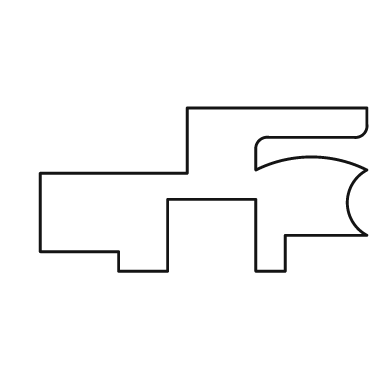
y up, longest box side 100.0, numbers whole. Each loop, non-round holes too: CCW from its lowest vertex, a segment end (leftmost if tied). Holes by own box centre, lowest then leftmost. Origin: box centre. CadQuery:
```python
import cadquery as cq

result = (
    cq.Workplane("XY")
    .moveTo(-26.0, -25.0)
    .lineTo(-11.0, -25.0)
    .lineTo(-11.0, -3.0)
    .lineTo(16.0, -3.0)
    .lineTo(16.0, -25.0)
    .lineTo(25.0, -25.0)
    .lineTo(25.0, -14.0)
    .lineTo(50.0, -14.0)
    .threePointArc((44.0, -4.0), (50.0, 6.0))
    .threePointArc((33.0, 10.0), (16.0, 6.0))
    .lineTo(16.0, 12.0)
    .threePointArc((17.0, 15.0), (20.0, 16.0))
    .lineTo(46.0, 16.0)
    .threePointArc((49.0, 17.0), (50.0, 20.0))
    .lineTo(50.0, 25.0)
    .lineTo(-5.0, 25.0)
    .lineTo(-5.0, 5.0)
    .lineTo(-50.0, 5.0)
    .lineTo(-50.0, -19.0)
    .lineTo(-26.0, -19.0)
    .close()
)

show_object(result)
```